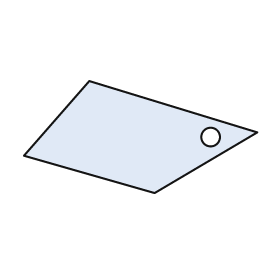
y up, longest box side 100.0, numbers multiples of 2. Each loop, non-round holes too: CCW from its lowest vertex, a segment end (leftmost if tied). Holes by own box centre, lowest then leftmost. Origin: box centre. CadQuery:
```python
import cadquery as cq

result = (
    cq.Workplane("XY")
    .moveTo(6.0, -24.0)
    .lineTo(50.0, 2.0)
    .lineTo(-22.0, 24.0)
    .lineTo(-50.0, -8.0)
    .close()
    .moveTo(30.0, 0.0)
    .circle(4.0)
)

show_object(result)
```